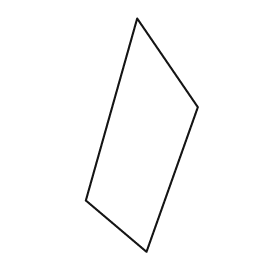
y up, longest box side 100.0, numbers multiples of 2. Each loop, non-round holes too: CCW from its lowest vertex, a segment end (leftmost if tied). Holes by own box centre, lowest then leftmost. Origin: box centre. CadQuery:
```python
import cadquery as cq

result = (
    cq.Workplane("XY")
    .moveTo(2.0, -50.0)
    .lineTo(24.0, 12.0)
    .lineTo(-2.0, 50.0)
    .lineTo(-24.0, -28.0)
    .close()
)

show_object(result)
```